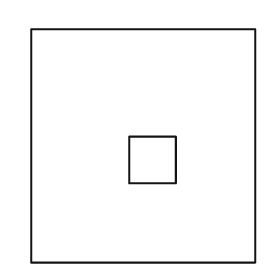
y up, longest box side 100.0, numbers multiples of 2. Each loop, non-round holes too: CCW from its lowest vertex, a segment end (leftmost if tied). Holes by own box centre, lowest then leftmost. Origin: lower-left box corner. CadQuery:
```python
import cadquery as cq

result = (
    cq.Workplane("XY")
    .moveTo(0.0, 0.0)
    .lineTo(96.0, 0.0)
    .lineTo(96.0, 100.0)
    .lineTo(0.0, 100.0)
    .close()
    .moveTo(42.0, 34.0)
    .lineTo(62.0, 34.0)
    .lineTo(62.0, 54.0)
    .lineTo(42.0, 54.0)
    .close()
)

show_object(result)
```